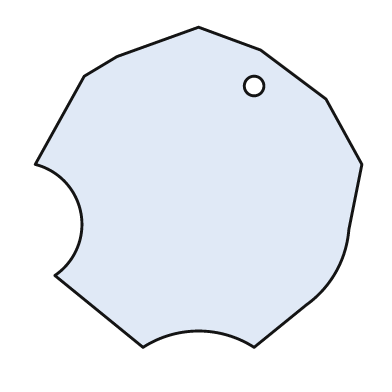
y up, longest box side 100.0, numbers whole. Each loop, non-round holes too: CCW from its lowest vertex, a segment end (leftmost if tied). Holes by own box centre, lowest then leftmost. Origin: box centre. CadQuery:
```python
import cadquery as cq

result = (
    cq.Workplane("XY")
    .moveTo(-17.0, -49.0)
    .threePointArc((0.0, -44.0), (17.0, -49.0))
    .lineTo(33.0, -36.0)
    .threePointArc((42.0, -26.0), (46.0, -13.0))
    .lineTo(50.0, 7.0)
    .lineTo(39.0, 27.0)
    .lineTo(19.0, 42.0)
    .lineTo(0.0, 49.0)
    .lineTo(-25.0, 40.0)
    .lineTo(-35.0, 34.0)
    .lineTo(-50.0, 7.0)
    .threePointArc((-36.0, -8.0), (-44.0, -27.0))
    .close()
    .moveTo(17.0, 31.0)
    .circle(3.0)
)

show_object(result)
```